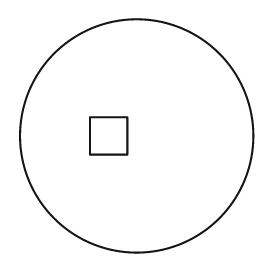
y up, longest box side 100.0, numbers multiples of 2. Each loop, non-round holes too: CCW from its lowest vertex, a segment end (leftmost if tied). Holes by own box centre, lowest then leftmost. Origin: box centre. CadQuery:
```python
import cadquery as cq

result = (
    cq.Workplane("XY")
    .moveTo(0.0, 0.0)
    .circle(50.0)
    .moveTo(-20.0, -8.0)
    .lineTo(-4.0, -8.0)
    .lineTo(-4.0, 8.0)
    .lineTo(-20.0, 8.0)
    .close()
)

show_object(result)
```